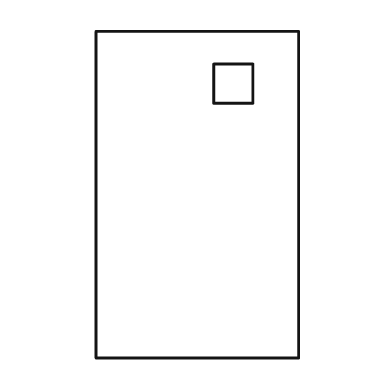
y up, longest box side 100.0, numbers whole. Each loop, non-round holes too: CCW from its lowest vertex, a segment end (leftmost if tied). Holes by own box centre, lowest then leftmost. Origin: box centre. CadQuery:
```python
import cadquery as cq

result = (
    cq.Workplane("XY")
    .moveTo(-31.0, -50.0)
    .lineTo(31.0, -50.0)
    .lineTo(31.0, 50.0)
    .lineTo(-31.0, 50.0)
    .close()
    .moveTo(5.0, 28.0)
    .lineTo(17.0, 28.0)
    .lineTo(17.0, 40.0)
    .lineTo(5.0, 40.0)
    .close()
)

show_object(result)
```